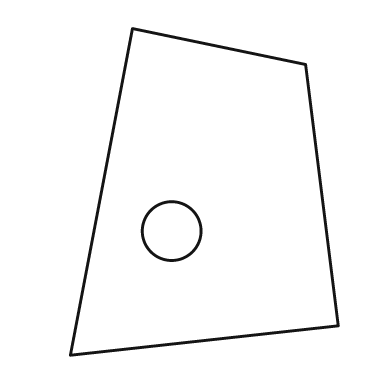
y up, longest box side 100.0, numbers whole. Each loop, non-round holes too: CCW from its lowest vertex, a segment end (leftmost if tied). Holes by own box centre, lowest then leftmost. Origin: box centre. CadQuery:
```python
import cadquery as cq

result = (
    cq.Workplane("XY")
    .moveTo(-41.0, -50.0)
    .lineTo(41.0, -41.0)
    .lineTo(31.0, 39.0)
    .lineTo(-22.0, 50.0)
    .close()
    .moveTo(-10.0, -12.0)
    .circle(9.0)
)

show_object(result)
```